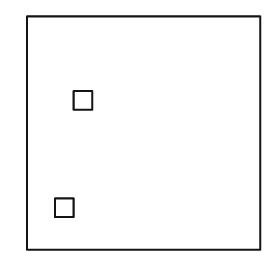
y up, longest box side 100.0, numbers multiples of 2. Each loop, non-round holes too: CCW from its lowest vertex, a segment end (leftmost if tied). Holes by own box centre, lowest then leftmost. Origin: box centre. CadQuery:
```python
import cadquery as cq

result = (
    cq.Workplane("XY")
    .moveTo(-50.0, -50.0)
    .lineTo(50.0, -50.0)
    .lineTo(50.0, 50.0)
    .lineTo(-50.0, 50.0)
    .close()
    .moveTo(-38.0, -36.0)
    .lineTo(-30.0, -36.0)
    .lineTo(-30.0, -28.0)
    .lineTo(-38.0, -28.0)
    .close()
    .moveTo(-30.0, 10.0)
    .lineTo(-22.0, 10.0)
    .lineTo(-22.0, 18.0)
    .lineTo(-30.0, 18.0)
    .close()
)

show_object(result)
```